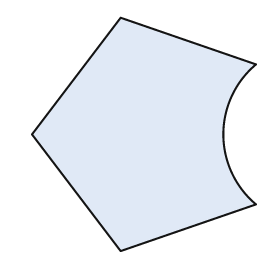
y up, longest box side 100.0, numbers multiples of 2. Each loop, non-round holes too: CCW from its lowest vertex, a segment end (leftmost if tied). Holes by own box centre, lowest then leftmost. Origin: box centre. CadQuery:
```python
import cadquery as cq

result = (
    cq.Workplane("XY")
    .moveTo(-10.0, -50.0)
    .lineTo(48.0, -30.0)
    .threePointArc((34.0, 0.0), (48.0, 30.0))
    .lineTo(-10.0, 50.0)
    .lineTo(-48.0, 0.0)
    .close()
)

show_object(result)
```